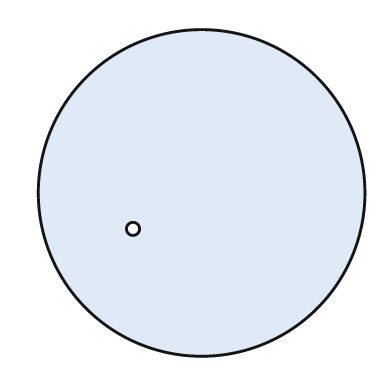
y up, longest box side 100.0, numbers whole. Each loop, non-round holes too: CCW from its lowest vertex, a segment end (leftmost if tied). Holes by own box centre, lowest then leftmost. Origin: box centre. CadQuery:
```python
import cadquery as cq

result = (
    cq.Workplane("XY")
    .moveTo(0.0, 0.0)
    .circle(50.0)
    .moveTo(-21.0, -11.0)
    .circle(2.0)
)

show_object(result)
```